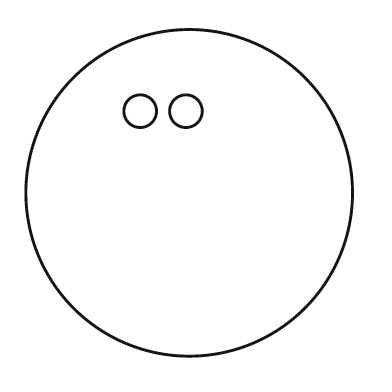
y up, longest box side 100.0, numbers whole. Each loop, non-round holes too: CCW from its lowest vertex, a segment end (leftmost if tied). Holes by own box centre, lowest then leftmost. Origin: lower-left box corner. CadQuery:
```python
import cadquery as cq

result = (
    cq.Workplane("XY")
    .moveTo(50.0, 50.0)
    .circle(50.0)
    .moveTo(35.0, 75.0)
    .circle(5.0)
    .moveTo(49.0, 75.0)
    .circle(5.0)
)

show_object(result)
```